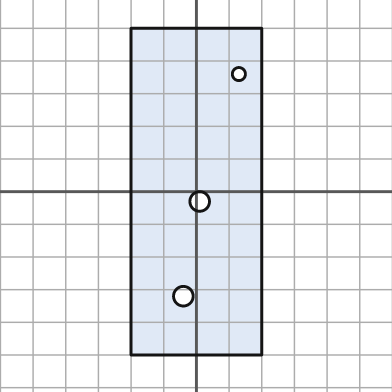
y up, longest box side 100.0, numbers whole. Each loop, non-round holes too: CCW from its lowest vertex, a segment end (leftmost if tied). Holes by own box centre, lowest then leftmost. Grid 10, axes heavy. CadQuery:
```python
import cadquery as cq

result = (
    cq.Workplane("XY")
    .moveTo(-20.0, -50.0)
    .lineTo(20.0, -50.0)
    .lineTo(20.0, 50.0)
    .lineTo(-20.0, 50.0)
    .close()
    .moveTo(-4.0, -32.0)
    .circle(3.0)
    .moveTo(1.0, -3.0)
    .circle(3.0)
    .moveTo(13.0, 36.0)
    .circle(2.0)
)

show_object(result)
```